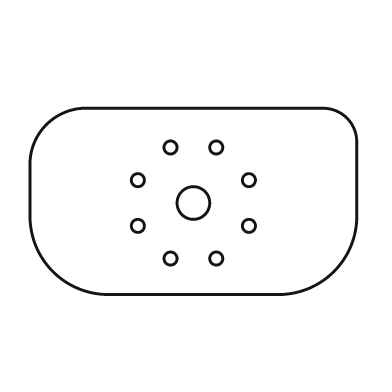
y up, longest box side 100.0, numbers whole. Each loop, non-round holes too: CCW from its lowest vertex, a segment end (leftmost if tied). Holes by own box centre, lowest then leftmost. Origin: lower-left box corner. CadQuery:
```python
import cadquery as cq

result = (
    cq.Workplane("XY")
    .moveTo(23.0, 0.0)
    .lineTo(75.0, 0.0)
    .threePointArc((93.0, 7.0), (100.0, 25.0))
    .lineTo(100.0, 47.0)
    .threePointArc((97.0, 54.0), (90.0, 57.0))
    .lineTo(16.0, 57.0)
    .threePointArc((5.0, 52.0), (0.0, 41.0))
    .lineTo(0.0, 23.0)
    .threePointArc((7.0, 7.0), (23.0, 0.0))
    .close()
    .moveTo(43.0, 11.0)
    .circle(2.0)
    .moveTo(57.0, 11.0)
    .circle(2.0)
    .moveTo(33.0, 21.0)
    .circle(2.0)
    .moveTo(67.0, 21.0)
    .circle(2.0)
    .moveTo(50.0, 28.0)
    .circle(5.0)
    .moveTo(33.0, 35.0)
    .circle(2.0)
    .moveTo(67.0, 35.0)
    .circle(2.0)
    .moveTo(43.0, 45.0)
    .circle(2.0)
    .moveTo(57.0, 45.0)
    .circle(2.0)
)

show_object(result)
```